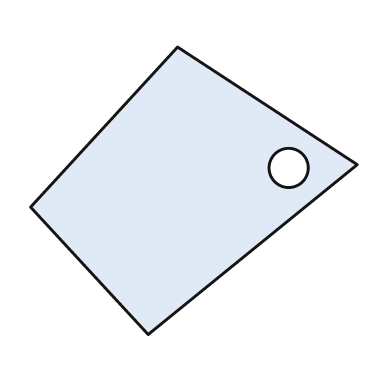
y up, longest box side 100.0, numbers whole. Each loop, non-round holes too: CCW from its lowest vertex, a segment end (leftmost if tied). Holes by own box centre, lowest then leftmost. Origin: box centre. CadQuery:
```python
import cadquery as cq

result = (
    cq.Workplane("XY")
    .moveTo(-14.0, -44.0)
    .lineTo(50.0, 8.0)
    .lineTo(-5.0, 44.0)
    .lineTo(-50.0, -5.0)
    .close()
    .moveTo(29.0, 7.0)
    .circle(6.0)
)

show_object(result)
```